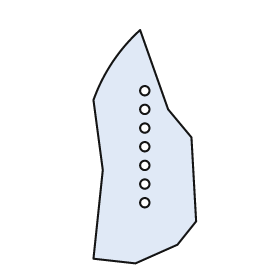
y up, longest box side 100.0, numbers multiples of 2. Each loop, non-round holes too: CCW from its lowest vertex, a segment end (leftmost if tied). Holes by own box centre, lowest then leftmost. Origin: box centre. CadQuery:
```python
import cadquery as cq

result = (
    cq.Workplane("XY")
    .moveTo(-4.0, -50.0)
    .lineTo(14.0, -42.0)
    .lineTo(22.0, -32.0)
    .lineTo(20.0, 4.0)
    .lineTo(10.0, 16.0)
    .lineTo(-2.0, 50.0)
    .threePointArc((-14.0, 36.0), (-22.0, 20.0))
    .lineTo(-18.0, -10.0)
    .lineTo(-22.0, -48.0)
    .close()
    .moveTo(0.0, -24.0)
    .circle(2.0)
    .moveTo(0.0, -16.0)
    .circle(2.0)
    .moveTo(0.0, -8.0)
    .circle(2.0)
    .moveTo(0.0, 0.0)
    .circle(2.0)
    .moveTo(0.0, 8.0)
    .circle(2.0)
    .moveTo(0.0, 16.0)
    .circle(2.0)
    .moveTo(0.0, 24.0)
    .circle(2.0)
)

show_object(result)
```